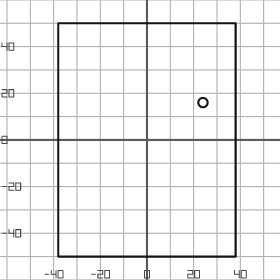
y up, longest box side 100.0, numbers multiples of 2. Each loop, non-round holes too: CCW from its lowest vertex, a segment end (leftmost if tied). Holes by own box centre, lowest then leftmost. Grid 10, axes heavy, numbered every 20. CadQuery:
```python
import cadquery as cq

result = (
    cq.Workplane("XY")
    .moveTo(-38.0, -50.0)
    .lineTo(38.0, -50.0)
    .lineTo(38.0, 50.0)
    .lineTo(-38.0, 50.0)
    .close()
    .moveTo(24.0, 16.0)
    .circle(2.0)
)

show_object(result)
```